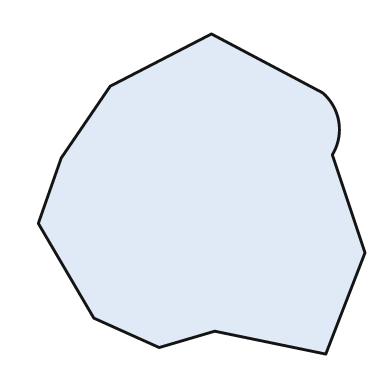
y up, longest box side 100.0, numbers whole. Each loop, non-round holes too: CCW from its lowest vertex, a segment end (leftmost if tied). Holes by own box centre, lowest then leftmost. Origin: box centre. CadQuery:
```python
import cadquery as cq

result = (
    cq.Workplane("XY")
    .moveTo(38.0, -49.0)
    .lineTo(50.0, -18.0)
    .lineTo(40.0, 12.0)
    .threePointArc((42.0, 22.0), (37.0, 31.0))
    .lineTo(3.0, 49.0)
    .lineTo(-28.0, 33.0)
    .lineTo(-43.0, 11.0)
    .lineTo(-50.0, -9.0)
    .lineTo(-33.0, -38.0)
    .lineTo(-13.0, -47.0)
    .lineTo(4.0, -42.0)
    .close()
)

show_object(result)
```